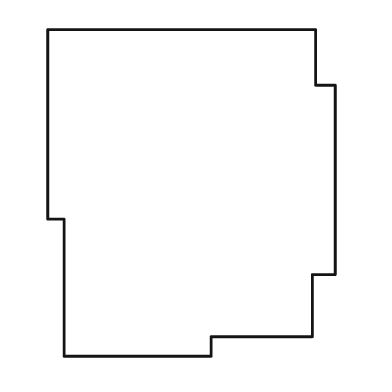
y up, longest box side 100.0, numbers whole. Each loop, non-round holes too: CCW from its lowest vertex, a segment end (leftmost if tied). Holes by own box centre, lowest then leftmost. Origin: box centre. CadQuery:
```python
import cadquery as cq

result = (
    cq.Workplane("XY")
    .moveTo(-39.0, -50.0)
    .lineTo(6.0, -50.0)
    .lineTo(6.0, -44.0)
    .lineTo(37.0, -44.0)
    .lineTo(37.0, -25.0)
    .lineTo(44.0, -25.0)
    .lineTo(44.0, 33.0)
    .lineTo(38.0, 33.0)
    .lineTo(38.0, 50.0)
    .lineTo(-44.0, 50.0)
    .lineTo(-44.0, -8.0)
    .lineTo(-39.0, -8.0)
    .close()
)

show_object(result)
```